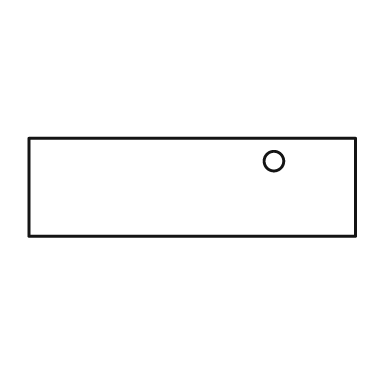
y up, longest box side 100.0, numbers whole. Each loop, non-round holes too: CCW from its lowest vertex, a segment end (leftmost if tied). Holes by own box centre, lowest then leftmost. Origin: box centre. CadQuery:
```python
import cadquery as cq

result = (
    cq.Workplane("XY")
    .moveTo(-50.0, -15.0)
    .lineTo(50.0, -15.0)
    .lineTo(50.0, 15.0)
    .lineTo(-50.0, 15.0)
    .close()
    .moveTo(25.0, 8.0)
    .circle(3.0)
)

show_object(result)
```